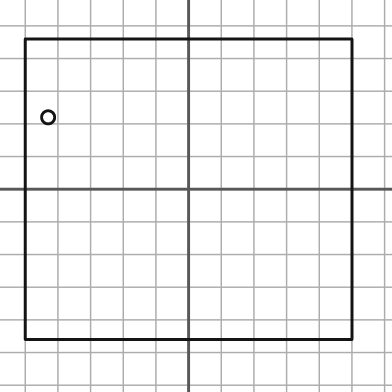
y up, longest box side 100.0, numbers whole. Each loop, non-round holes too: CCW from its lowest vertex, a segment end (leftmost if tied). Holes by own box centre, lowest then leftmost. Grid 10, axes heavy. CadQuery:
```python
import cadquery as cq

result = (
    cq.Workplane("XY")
    .moveTo(-50.0, -46.0)
    .lineTo(50.0, -46.0)
    .lineTo(50.0, 46.0)
    .lineTo(-50.0, 46.0)
    .close()
    .moveTo(-43.0, 22.0)
    .circle(2.0)
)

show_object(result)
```